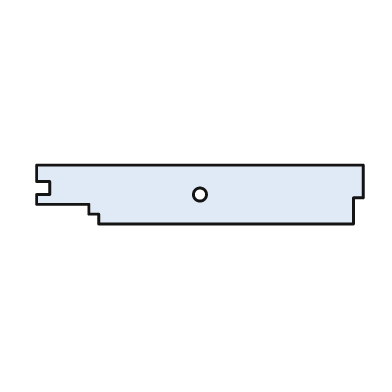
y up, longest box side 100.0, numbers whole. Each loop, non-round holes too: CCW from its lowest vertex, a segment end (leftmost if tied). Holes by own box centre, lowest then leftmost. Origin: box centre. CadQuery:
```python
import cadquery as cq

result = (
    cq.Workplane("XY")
    .moveTo(-31.0, -9.0)
    .lineTo(47.0, -9.0)
    .lineTo(47.0, -1.0)
    .lineTo(50.0, -1.0)
    .lineTo(50.0, 9.0)
    .lineTo(-50.0, 9.0)
    .lineTo(-50.0, 4.0)
    .lineTo(-46.0, 4.0)
    .lineTo(-46.0, 0.0)
    .lineTo(-50.0, 0.0)
    .lineTo(-50.0, -3.0)
    .lineTo(-34.0, -3.0)
    .lineTo(-34.0, -6.0)
    .lineTo(-31.0, -6.0)
    .close()
    .moveTo(0.0, 0.0)
    .circle(2.0)
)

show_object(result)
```